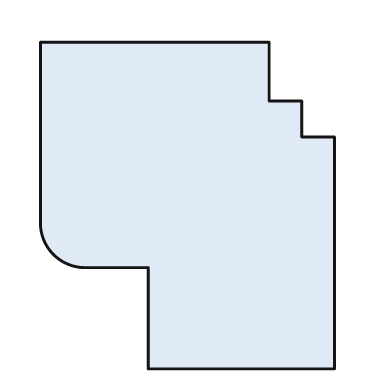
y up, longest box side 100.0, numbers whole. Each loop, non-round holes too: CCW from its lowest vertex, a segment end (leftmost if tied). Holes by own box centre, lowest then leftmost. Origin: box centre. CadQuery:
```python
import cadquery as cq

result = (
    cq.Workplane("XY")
    .moveTo(-12.0, -50.0)
    .lineTo(45.0, -50.0)
    .lineTo(45.0, 21.0)
    .lineTo(35.0, 21.0)
    .lineTo(35.0, 32.0)
    .lineTo(25.0, 32.0)
    .lineTo(25.0, 50.0)
    .lineTo(-45.0, 50.0)
    .lineTo(-45.0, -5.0)
    .threePointArc((-41.0, -15.0), (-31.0, -19.0))
    .lineTo(-12.0, -19.0)
    .close()
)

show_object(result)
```